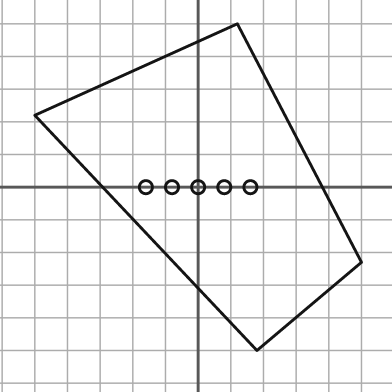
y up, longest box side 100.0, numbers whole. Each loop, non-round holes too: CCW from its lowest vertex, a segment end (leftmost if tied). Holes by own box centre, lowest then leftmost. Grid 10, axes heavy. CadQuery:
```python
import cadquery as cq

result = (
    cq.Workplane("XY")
    .moveTo(18.0, -50.0)
    .lineTo(50.0, -23.0)
    .lineTo(12.0, 50.0)
    .lineTo(-50.0, 22.0)
    .close()
    .moveTo(-16.0, 0.0)
    .circle(2.0)
    .moveTo(-8.0, 0.0)
    .circle(2.0)
    .moveTo(0.0, 0.0)
    .circle(2.0)
    .moveTo(8.0, 0.0)
    .circle(2.0)
    .moveTo(16.0, 0.0)
    .circle(2.0)
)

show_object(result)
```